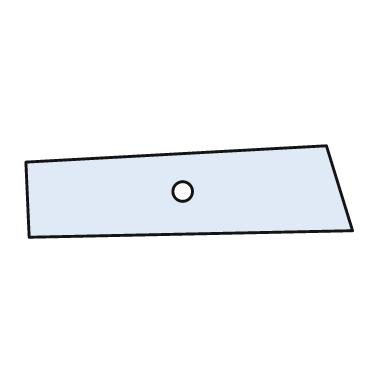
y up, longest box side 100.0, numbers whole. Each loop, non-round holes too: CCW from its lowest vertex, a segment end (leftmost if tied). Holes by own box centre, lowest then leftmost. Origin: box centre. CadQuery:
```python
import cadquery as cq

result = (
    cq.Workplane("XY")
    .moveTo(-49.0, -14.0)
    .lineTo(50.0, -12.0)
    .lineTo(42.0, 14.0)
    .lineTo(-50.0, 9.0)
    .close()
    .moveTo(-2.0, 0.0)
    .circle(3.0)
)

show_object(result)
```